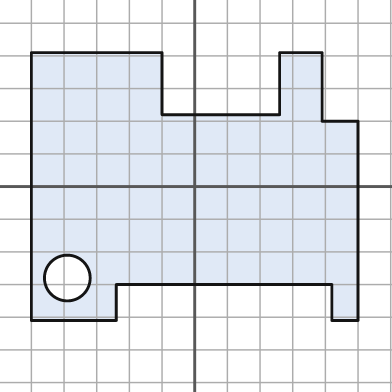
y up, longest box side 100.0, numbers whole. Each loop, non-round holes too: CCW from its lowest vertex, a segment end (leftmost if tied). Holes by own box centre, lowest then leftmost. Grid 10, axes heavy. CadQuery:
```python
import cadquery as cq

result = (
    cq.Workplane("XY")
    .moveTo(-50.0, -41.0)
    .lineTo(-24.0, -41.0)
    .lineTo(-24.0, -30.0)
    .lineTo(42.0, -30.0)
    .lineTo(42.0, -41.0)
    .lineTo(50.0, -41.0)
    .lineTo(50.0, 20.0)
    .lineTo(39.0, 20.0)
    .lineTo(39.0, 41.0)
    .lineTo(26.0, 41.0)
    .lineTo(26.0, 22.0)
    .lineTo(-10.0, 22.0)
    .lineTo(-10.0, 41.0)
    .lineTo(-50.0, 41.0)
    .close()
    .moveTo(-39.0, -28.0)
    .circle(7.0)
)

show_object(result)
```